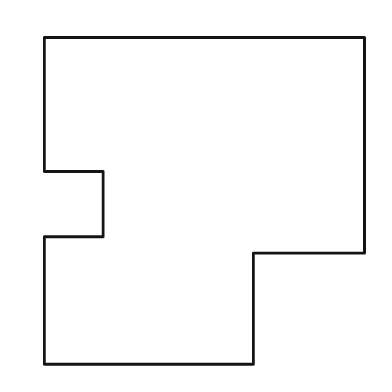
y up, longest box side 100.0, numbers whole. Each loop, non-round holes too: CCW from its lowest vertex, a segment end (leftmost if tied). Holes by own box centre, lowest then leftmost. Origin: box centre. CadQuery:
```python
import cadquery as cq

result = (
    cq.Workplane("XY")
    .moveTo(-49.0, -50.0)
    .lineTo(15.0, -50.0)
    .lineTo(15.0, -16.0)
    .lineTo(49.0, -16.0)
    .lineTo(49.0, 50.0)
    .lineTo(-49.0, 50.0)
    .lineTo(-49.0, 9.0)
    .lineTo(-31.0, 9.0)
    .lineTo(-31.0, -11.0)
    .lineTo(-49.0, -11.0)
    .close()
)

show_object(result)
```